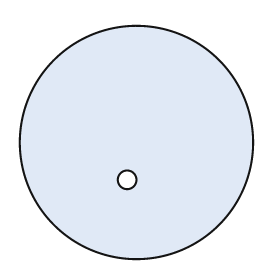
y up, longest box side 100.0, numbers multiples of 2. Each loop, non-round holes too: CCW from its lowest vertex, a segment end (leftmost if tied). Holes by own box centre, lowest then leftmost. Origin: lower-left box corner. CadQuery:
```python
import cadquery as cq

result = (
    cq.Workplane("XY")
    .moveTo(50.0, 50.0)
    .circle(50.0)
    .moveTo(46.0, 34.0)
    .circle(4.0)
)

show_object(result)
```